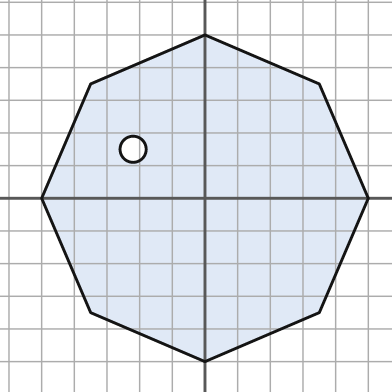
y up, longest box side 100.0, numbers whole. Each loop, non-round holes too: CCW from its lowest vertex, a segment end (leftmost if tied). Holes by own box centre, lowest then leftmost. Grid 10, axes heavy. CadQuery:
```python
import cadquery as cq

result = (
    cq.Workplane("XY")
    .moveTo(0.0, -50.0)
    .lineTo(35.0, -35.0)
    .lineTo(50.0, 0.0)
    .lineTo(35.0, 35.0)
    .lineTo(0.0, 50.0)
    .lineTo(-35.0, 35.0)
    .lineTo(-50.0, 0.0)
    .lineTo(-35.0, -35.0)
    .close()
    .moveTo(-22.0, 15.0)
    .circle(4.0)
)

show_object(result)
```